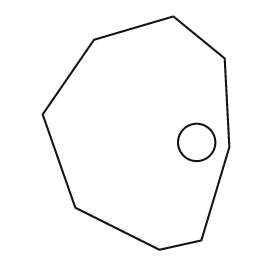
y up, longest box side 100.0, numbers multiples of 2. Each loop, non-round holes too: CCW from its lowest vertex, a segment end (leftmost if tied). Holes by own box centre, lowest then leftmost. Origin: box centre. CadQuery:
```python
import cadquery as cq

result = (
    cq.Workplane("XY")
    .moveTo(10.0, -50.0)
    .lineTo(28.0, -46.0)
    .lineTo(40.0, -6.0)
    .lineTo(38.0, 32.0)
    .lineTo(16.0, 50.0)
    .lineTo(-18.0, 40.0)
    .lineTo(-40.0, 8.0)
    .lineTo(-26.0, -32.0)
    .close()
    .moveTo(26.0, -4.0)
    .circle(8.0)
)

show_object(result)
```